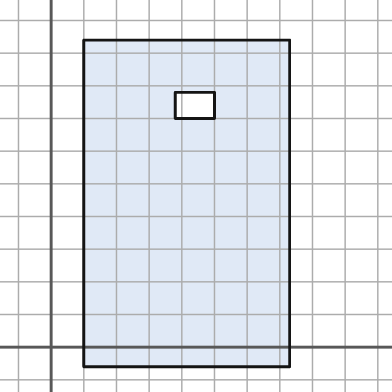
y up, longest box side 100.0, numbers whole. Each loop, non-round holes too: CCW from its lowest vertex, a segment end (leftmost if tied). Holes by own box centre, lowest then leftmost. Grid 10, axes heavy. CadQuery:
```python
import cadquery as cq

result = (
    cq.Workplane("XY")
    .moveTo(10.0, -6.0)
    .lineTo(73.0, -6.0)
    .lineTo(73.0, 94.0)
    .lineTo(10.0, 94.0)
    .close()
    .moveTo(38.0, 70.0)
    .lineTo(50.0, 70.0)
    .lineTo(50.0, 78.0)
    .lineTo(38.0, 78.0)
    .close()
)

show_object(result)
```